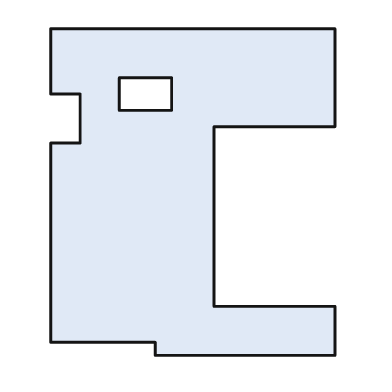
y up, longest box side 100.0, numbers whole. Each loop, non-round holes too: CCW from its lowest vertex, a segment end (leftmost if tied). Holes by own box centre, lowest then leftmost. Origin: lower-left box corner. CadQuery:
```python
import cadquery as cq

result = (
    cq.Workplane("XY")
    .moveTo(32.0, 0.0)
    .lineTo(87.0, 0.0)
    .lineTo(87.0, 15.0)
    .lineTo(50.0, 15.0)
    .lineTo(50.0, 70.0)
    .lineTo(87.0, 70.0)
    .lineTo(87.0, 100.0)
    .lineTo(0.0, 100.0)
    .lineTo(0.0, 80.0)
    .lineTo(9.0, 80.0)
    .lineTo(9.0, 65.0)
    .lineTo(0.0, 65.0)
    .lineTo(0.0, 4.0)
    .lineTo(32.0, 4.0)
    .close()
    .moveTo(21.0, 75.0)
    .lineTo(37.0, 75.0)
    .lineTo(37.0, 85.0)
    .lineTo(21.0, 85.0)
    .close()
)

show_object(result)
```